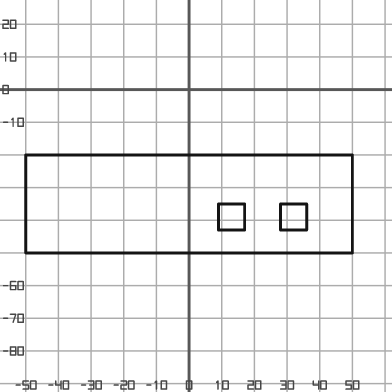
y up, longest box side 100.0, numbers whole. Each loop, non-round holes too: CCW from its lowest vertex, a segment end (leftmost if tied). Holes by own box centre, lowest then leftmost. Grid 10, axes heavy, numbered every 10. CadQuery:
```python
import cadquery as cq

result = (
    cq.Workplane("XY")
    .moveTo(-50.0, -50.0)
    .lineTo(50.0, -50.0)
    .lineTo(50.0, -20.0)
    .lineTo(-50.0, -20.0)
    .close()
    .moveTo(9.0, -43.0)
    .lineTo(17.0, -43.0)
    .lineTo(17.0, -35.0)
    .lineTo(9.0, -35.0)
    .close()
    .moveTo(28.0, -43.0)
    .lineTo(36.0, -43.0)
    .lineTo(36.0, -35.0)
    .lineTo(28.0, -35.0)
    .close()
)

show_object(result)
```